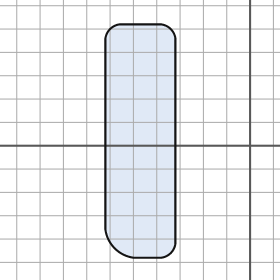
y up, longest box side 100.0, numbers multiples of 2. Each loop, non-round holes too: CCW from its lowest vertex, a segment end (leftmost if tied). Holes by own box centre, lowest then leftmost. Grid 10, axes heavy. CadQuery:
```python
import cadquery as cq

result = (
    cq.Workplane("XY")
    .moveTo(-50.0, -48.0)
    .lineTo(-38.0, -48.0)
    .threePointArc((-34.0, -46.0), (-32.0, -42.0))
    .lineTo(-32.0, 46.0)
    .threePointArc((-34.0, 50.0), (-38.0, 52.0))
    .lineTo(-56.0, 52.0)
    .threePointArc((-60.0, 50.0), (-62.0, 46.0))
    .lineTo(-62.0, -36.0)
    .threePointArc((-58.0, -44.0), (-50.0, -48.0))
    .close()
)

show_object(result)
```